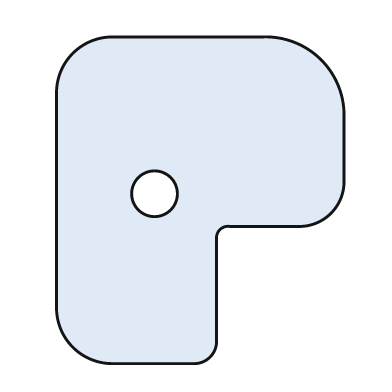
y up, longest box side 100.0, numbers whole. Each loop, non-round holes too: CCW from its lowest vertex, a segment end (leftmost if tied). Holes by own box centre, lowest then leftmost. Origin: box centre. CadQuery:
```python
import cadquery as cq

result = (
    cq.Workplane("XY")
    .moveTo(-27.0, -50.0)
    .lineTo(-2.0, -50.0)
    .threePointArc((3.0, -48.0), (5.0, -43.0))
    .lineTo(5.0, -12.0)
    .threePointArc((6.0, -9.0), (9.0, -8.0))
    .lineTo(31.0, -8.0)
    .threePointArc((40.0, -4.0), (44.0, 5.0))
    .lineTo(44.0, 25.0)
    .threePointArc((37.0, 43.0), (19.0, 50.0))
    .lineTo(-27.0, 50.0)
    .threePointArc((-39.0, 45.0), (-44.0, 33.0))
    .lineTo(-44.0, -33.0)
    .threePointArc((-39.0, -45.0), (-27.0, -50.0))
    .close()
    .moveTo(-14.0, 2.0)
    .circle(7.0)
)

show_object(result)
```